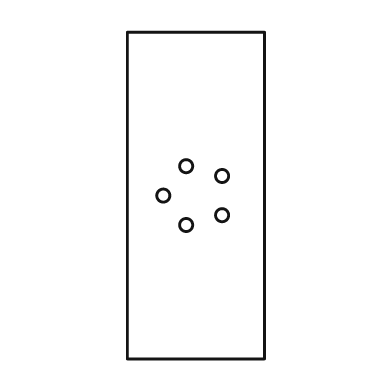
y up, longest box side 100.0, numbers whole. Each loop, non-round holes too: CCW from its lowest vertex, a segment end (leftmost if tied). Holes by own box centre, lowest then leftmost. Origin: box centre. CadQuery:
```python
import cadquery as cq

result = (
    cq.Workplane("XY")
    .moveTo(-21.0, -50.0)
    .lineTo(21.0, -50.0)
    .lineTo(21.0, 50.0)
    .lineTo(-21.0, 50.0)
    .close()
    .moveTo(-3.0, -9.0)
    .circle(2.0)
    .moveTo(8.0, -6.0)
    .circle(2.0)
    .moveTo(-10.0, 0.0)
    .circle(2.0)
    .moveTo(8.0, 6.0)
    .circle(2.0)
    .moveTo(-3.0, 9.0)
    .circle(2.0)
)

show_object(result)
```